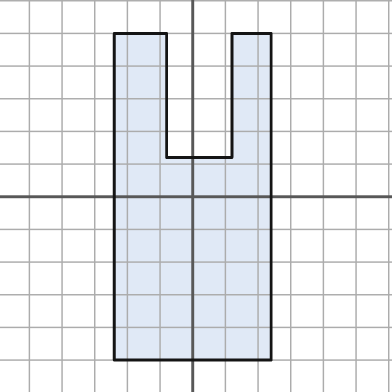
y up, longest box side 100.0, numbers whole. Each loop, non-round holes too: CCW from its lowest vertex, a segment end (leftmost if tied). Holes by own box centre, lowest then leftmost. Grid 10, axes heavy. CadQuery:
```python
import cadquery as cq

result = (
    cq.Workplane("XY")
    .moveTo(-24.0, -50.0)
    .lineTo(24.0, -50.0)
    .lineTo(24.0, 50.0)
    .lineTo(12.0, 50.0)
    .lineTo(12.0, 12.0)
    .lineTo(-8.0, 12.0)
    .lineTo(-8.0, 50.0)
    .lineTo(-24.0, 50.0)
    .close()
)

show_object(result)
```